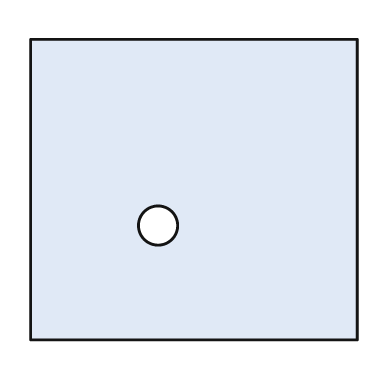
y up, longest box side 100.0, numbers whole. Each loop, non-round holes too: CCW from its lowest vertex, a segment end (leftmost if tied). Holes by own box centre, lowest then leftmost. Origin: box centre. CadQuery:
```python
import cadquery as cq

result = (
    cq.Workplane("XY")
    .moveTo(-50.0, -46.0)
    .lineTo(50.0, -46.0)
    .lineTo(50.0, 46.0)
    .lineTo(-50.0, 46.0)
    .close()
    .moveTo(-11.0, -11.0)
    .circle(6.0)
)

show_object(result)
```